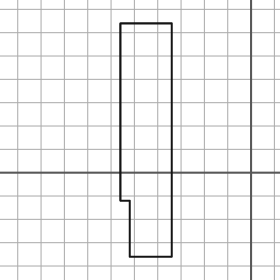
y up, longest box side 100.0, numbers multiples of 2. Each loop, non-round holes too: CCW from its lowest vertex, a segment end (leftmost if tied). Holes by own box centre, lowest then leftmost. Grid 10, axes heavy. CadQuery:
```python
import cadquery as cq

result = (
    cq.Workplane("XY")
    .moveTo(-52.0, -36.0)
    .lineTo(-34.0, -36.0)
    .lineTo(-34.0, 64.0)
    .lineTo(-56.0, 64.0)
    .lineTo(-56.0, -12.0)
    .lineTo(-52.0, -12.0)
    .close()
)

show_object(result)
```